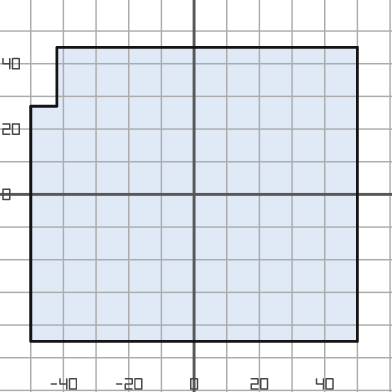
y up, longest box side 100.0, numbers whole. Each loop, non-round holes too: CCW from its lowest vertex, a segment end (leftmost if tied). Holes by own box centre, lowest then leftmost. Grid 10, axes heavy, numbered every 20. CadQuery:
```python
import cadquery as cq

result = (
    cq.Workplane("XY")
    .moveTo(-50.0, -45.0)
    .lineTo(50.0, -45.0)
    .lineTo(50.0, 45.0)
    .lineTo(-42.0, 45.0)
    .lineTo(-42.0, 27.0)
    .lineTo(-50.0, 27.0)
    .close()
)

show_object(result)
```